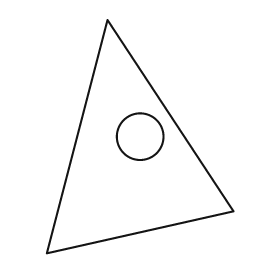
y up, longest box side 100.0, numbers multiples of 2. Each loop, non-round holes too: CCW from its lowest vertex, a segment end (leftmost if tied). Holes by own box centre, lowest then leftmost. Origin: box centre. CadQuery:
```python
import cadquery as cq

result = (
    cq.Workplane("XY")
    .moveTo(-40.0, -50.0)
    .lineTo(40.0, -32.0)
    .lineTo(-14.0, 50.0)
    .close()
    .moveTo(0.0, 0.0)
    .circle(10.0)
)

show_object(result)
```